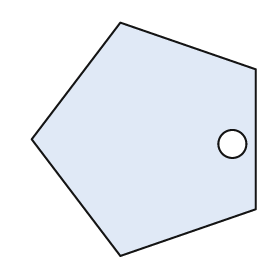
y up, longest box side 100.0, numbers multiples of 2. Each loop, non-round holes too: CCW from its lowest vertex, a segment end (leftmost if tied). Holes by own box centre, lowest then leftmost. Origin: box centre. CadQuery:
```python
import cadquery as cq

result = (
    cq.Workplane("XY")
    .moveTo(-10.0, -50.0)
    .lineTo(48.0, -30.0)
    .lineTo(48.0, 30.0)
    .lineTo(-10.0, 50.0)
    .lineTo(-48.0, 0.0)
    .close()
    .moveTo(38.0, -2.0)
    .circle(6.0)
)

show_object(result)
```